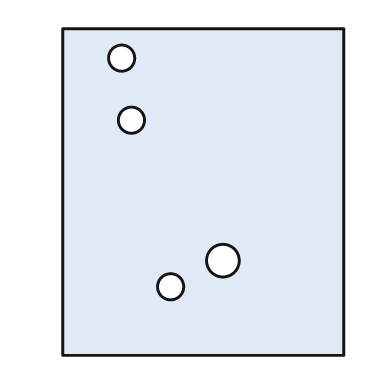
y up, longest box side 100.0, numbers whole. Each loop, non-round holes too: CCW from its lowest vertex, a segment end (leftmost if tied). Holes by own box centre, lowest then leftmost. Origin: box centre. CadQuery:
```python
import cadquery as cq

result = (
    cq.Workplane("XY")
    .moveTo(-43.0, -50.0)
    .lineTo(43.0, -50.0)
    .lineTo(43.0, 50.0)
    .lineTo(-43.0, 50.0)
    .close()
    .moveTo(-10.0, -29.0)
    .circle(4.0)
    .moveTo(6.0, -21.0)
    .circle(5.0)
    .moveTo(-22.0, 22.0)
    .circle(4.0)
    .moveTo(-25.0, 41.0)
    .circle(4.0)
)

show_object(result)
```